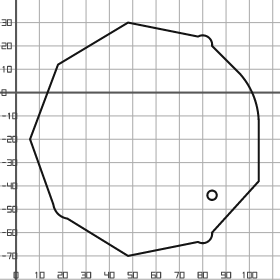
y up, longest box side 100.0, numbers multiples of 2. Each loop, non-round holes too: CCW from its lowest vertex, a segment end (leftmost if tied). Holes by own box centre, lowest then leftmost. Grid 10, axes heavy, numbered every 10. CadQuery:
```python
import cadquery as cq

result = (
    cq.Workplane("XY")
    .moveTo(48.0, -70.0)
    .lineTo(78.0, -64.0)
    .threePointArc((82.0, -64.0), (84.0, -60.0))
    .lineTo(104.0, -38.0)
    .lineTo(104.0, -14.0)
    .threePointArc((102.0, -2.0), (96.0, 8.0))
    .lineTo(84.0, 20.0)
    .threePointArc((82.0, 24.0), (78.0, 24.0))
    .lineTo(48.0, 30.0)
    .lineTo(18.0, 12.0)
    .lineTo(6.0, -20.0)
    .lineTo(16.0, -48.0)
    .threePointArc((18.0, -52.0), (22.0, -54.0))
    .close()
    .moveTo(84.0, -44.0)
    .circle(2.0)
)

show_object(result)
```